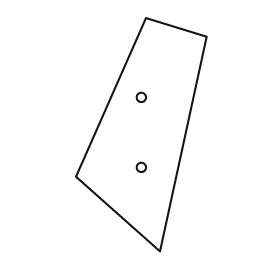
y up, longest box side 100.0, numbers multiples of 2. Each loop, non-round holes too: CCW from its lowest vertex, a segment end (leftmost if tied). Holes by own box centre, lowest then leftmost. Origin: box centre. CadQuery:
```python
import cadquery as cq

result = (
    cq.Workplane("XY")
    .moveTo(8.0, -50.0)
    .lineTo(28.0, 42.0)
    .lineTo(2.0, 50.0)
    .lineTo(-28.0, -18.0)
    .close()
    .moveTo(0.0, -14.0)
    .circle(2.0)
    .moveTo(0.0, 16.0)
    .circle(2.0)
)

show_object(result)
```